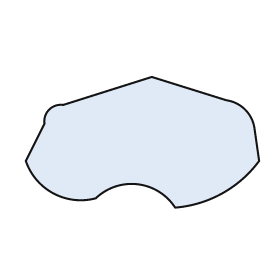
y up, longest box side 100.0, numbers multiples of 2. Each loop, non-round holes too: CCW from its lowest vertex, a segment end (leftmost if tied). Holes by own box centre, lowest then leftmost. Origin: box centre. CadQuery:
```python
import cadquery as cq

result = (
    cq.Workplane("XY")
    .moveTo(14.0, -28.0)
    .threePointArc((34.0, -22.0), (50.0, -8.0))
    .lineTo(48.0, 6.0)
    .threePointArc((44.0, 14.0), (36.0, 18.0))
    .lineTo(4.0, 28.0)
    .lineTo(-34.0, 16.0)
    .threePointArc((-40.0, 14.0), (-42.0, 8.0))
    .lineTo(-50.0, -8.0)
    .threePointArc((-38.0, -22.0), (-20.0, -24.0))
    .threePointArc((-2.0, -18.0), (14.0, -28.0))
    .close()
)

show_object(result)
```